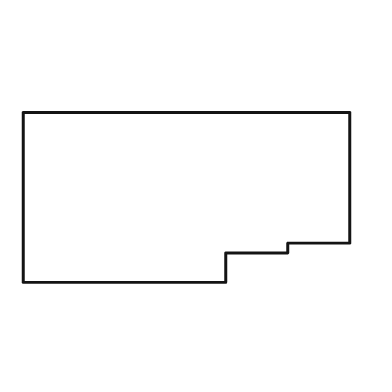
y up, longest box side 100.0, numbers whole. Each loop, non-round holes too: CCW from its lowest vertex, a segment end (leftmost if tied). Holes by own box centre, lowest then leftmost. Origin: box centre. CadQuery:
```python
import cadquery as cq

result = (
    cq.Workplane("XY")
    .moveTo(-50.0, -26.0)
    .lineTo(12.0, -26.0)
    .lineTo(12.0, -17.0)
    .lineTo(31.0, -17.0)
    .lineTo(31.0, -14.0)
    .lineTo(50.0, -14.0)
    .lineTo(50.0, 26.0)
    .lineTo(-50.0, 26.0)
    .close()
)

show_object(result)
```